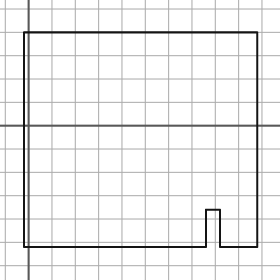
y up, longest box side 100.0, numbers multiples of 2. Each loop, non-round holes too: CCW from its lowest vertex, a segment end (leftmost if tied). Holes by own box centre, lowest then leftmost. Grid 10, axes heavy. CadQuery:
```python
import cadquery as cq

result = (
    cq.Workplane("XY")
    .moveTo(-2.0, -52.0)
    .lineTo(76.0, -52.0)
    .lineTo(76.0, -36.0)
    .lineTo(82.0, -36.0)
    .lineTo(82.0, -52.0)
    .lineTo(98.0, -52.0)
    .lineTo(98.0, 40.0)
    .lineTo(-2.0, 40.0)
    .close()
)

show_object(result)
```